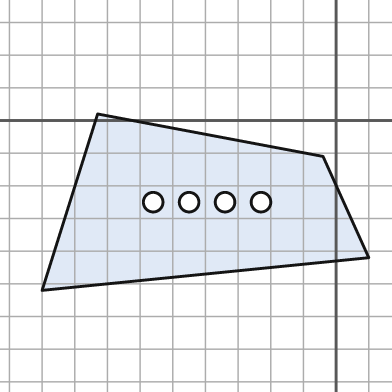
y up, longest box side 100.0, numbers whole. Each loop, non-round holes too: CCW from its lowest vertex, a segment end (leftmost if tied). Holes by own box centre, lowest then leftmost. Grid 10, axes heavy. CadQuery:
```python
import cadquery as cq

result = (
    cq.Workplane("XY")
    .moveTo(-90.0, -52.0)
    .lineTo(10.0, -42.0)
    .lineTo(-4.0, -11.0)
    .lineTo(-73.0, 2.0)
    .close()
    .moveTo(-56.0, -25.0)
    .circle(3.0)
    .moveTo(-45.0, -25.0)
    .circle(3.0)
    .moveTo(-34.0, -25.0)
    .circle(3.0)
    .moveTo(-23.0, -25.0)
    .circle(3.0)
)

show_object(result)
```